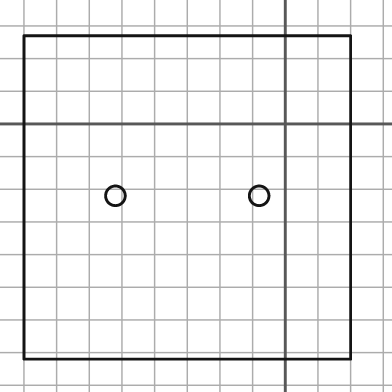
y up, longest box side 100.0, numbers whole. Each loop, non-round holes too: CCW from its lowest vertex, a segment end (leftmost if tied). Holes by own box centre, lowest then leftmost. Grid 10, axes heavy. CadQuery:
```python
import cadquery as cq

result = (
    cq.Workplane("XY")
    .moveTo(-80.0, -72.0)
    .lineTo(20.0, -72.0)
    .lineTo(20.0, 27.0)
    .lineTo(-80.0, 27.0)
    .close()
    .moveTo(-52.0, -22.0)
    .circle(3.0)
    .moveTo(-8.0, -22.0)
    .circle(3.0)
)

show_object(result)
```